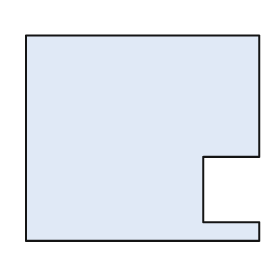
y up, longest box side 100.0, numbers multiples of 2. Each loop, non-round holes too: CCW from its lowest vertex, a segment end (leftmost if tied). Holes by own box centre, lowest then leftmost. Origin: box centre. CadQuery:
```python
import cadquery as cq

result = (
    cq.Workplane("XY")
    .moveTo(-50.0, -44.0)
    .lineTo(50.0, -44.0)
    .lineTo(50.0, -36.0)
    .lineTo(26.0, -36.0)
    .lineTo(26.0, -8.0)
    .lineTo(50.0, -8.0)
    .lineTo(50.0, 44.0)
    .lineTo(-50.0, 44.0)
    .close()
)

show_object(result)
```